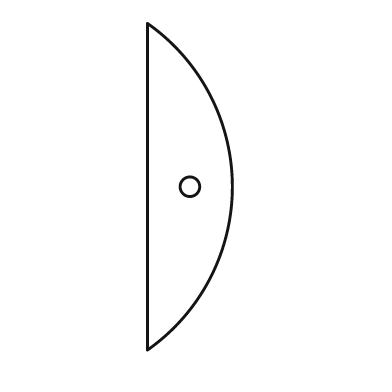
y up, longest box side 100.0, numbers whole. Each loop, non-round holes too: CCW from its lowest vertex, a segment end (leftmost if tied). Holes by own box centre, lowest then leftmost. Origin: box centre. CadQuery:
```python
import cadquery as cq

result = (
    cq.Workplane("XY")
    .moveTo(-13.0, -50.0)
    .threePointArc((13.0, 0.0), (-13.0, 50.0))
    .close()
    .moveTo(0.0, 0.0)
    .circle(3.0)
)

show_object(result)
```